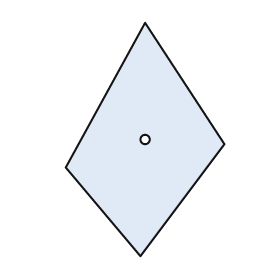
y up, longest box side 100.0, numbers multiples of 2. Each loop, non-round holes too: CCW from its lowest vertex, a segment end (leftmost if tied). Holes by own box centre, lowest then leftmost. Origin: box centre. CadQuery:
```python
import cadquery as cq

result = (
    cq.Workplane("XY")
    .moveTo(-2.0, -50.0)
    .lineTo(34.0, -2.0)
    .lineTo(0.0, 50.0)
    .lineTo(-34.0, -12.0)
    .close()
    .moveTo(0.0, 0.0)
    .circle(2.0)
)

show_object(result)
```